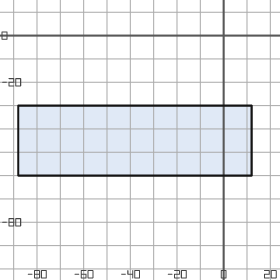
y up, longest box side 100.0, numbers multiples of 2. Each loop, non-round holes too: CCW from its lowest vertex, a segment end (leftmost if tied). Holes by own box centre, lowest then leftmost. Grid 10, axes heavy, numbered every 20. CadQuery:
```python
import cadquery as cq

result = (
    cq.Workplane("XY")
    .moveTo(-88.0, -60.0)
    .lineTo(12.0, -60.0)
    .lineTo(12.0, -30.0)
    .lineTo(-88.0, -30.0)
    .close()
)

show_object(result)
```